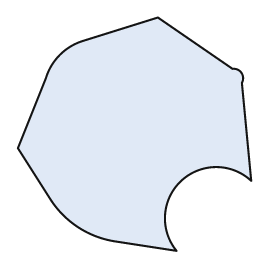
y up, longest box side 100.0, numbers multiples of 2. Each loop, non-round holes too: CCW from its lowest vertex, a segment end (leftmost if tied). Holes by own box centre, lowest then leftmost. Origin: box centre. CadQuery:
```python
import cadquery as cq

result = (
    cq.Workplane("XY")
    .moveTo(18.0, -50.0)
    .threePointArc((20.0, -20.0), (50.0, -20.0))
    .lineTo(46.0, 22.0)
    .threePointArc((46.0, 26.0), (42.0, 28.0))
    .lineTo(10.0, 50.0)
    .lineTo(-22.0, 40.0)
    .threePointArc((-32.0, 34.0), (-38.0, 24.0))
    .lineTo(-50.0, -6.0)
    .lineTo(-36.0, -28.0)
    .threePointArc((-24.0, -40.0), (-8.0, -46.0))
    .close()
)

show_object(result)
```